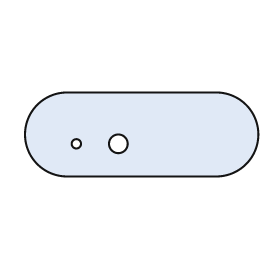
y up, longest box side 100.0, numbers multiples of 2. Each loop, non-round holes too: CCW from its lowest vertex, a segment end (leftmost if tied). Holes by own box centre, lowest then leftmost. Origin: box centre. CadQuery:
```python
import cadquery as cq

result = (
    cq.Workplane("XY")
    .moveTo(-32.0, -18.0)
    .lineTo(32.0, -18.0)
    .threePointArc((50.0, 0.0), (32.0, 18.0))
    .lineTo(-32.0, 18.0)
    .threePointArc((-50.0, 0.0), (-32.0, -18.0))
    .close()
    .moveTo(-28.0, -4.0)
    .circle(2.0)
    .moveTo(-10.0, -4.0)
    .circle(4.0)
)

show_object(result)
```